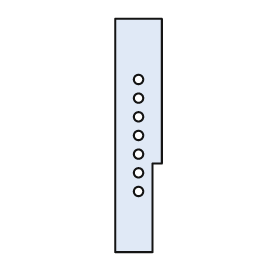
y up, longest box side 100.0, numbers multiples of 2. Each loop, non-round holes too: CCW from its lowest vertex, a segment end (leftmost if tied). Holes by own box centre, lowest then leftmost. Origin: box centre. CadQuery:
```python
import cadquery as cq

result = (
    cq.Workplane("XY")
    .moveTo(-10.0, -50.0)
    .lineTo(6.0, -50.0)
    .lineTo(6.0, -12.0)
    .lineTo(10.0, -12.0)
    .lineTo(10.0, 50.0)
    .lineTo(-10.0, 50.0)
    .close()
    .moveTo(0.0, -24.0)
    .circle(2.0)
    .moveTo(0.0, -16.0)
    .circle(2.0)
    .moveTo(0.0, -8.0)
    .circle(2.0)
    .moveTo(0.0, 0.0)
    .circle(2.0)
    .moveTo(0.0, 8.0)
    .circle(2.0)
    .moveTo(0.0, 16.0)
    .circle(2.0)
    .moveTo(0.0, 24.0)
    .circle(2.0)
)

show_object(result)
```